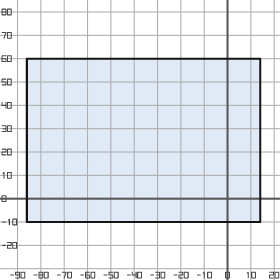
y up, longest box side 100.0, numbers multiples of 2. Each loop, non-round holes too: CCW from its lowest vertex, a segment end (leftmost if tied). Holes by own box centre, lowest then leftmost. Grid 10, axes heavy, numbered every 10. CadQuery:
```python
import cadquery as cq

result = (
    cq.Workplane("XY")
    .moveTo(-86.0, -10.0)
    .lineTo(14.0, -10.0)
    .lineTo(14.0, 60.0)
    .lineTo(-86.0, 60.0)
    .close()
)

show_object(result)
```